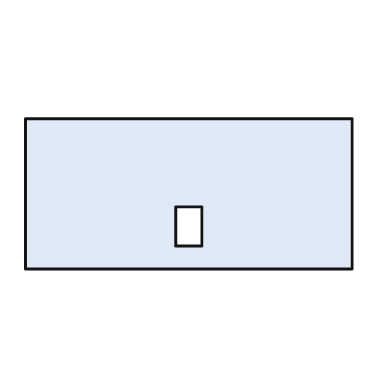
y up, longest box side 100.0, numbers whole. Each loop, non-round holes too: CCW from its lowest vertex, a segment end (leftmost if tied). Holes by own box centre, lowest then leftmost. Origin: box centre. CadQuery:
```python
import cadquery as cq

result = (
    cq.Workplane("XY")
    .moveTo(-50.0, -23.0)
    .lineTo(50.0, -23.0)
    .lineTo(50.0, 23.0)
    .lineTo(-50.0, 23.0)
    .close()
    .moveTo(-4.0, -16.0)
    .lineTo(4.0, -16.0)
    .lineTo(4.0, -4.0)
    .lineTo(-4.0, -4.0)
    .close()
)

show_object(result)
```